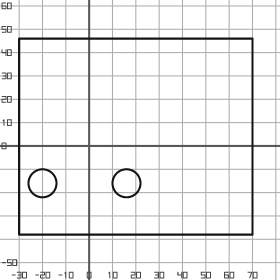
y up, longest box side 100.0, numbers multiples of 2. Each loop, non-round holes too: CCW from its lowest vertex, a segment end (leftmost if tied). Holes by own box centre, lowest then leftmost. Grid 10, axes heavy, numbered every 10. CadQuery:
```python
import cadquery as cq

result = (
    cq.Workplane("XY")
    .moveTo(-30.0, -38.0)
    .lineTo(70.0, -38.0)
    .lineTo(70.0, 46.0)
    .lineTo(-30.0, 46.0)
    .close()
    .moveTo(-20.0, -16.0)
    .circle(6.0)
    .moveTo(16.0, -16.0)
    .circle(6.0)
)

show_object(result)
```